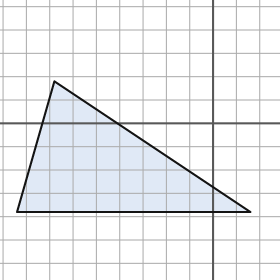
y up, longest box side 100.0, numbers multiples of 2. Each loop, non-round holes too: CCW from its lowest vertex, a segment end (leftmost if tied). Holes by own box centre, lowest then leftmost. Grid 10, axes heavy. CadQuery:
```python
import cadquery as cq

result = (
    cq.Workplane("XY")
    .moveTo(-84.0, -38.0)
    .lineTo(16.0, -38.0)
    .lineTo(-68.0, 18.0)
    .close()
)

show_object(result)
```